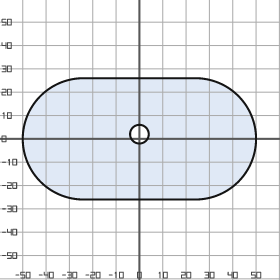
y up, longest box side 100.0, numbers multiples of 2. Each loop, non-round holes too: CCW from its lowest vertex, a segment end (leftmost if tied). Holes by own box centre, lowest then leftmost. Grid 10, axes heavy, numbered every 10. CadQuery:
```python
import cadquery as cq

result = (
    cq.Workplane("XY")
    .moveTo(-24.0, -26.0)
    .lineTo(24.0, -26.0)
    .threePointArc((50.0, 0.0), (24.0, 26.0))
    .lineTo(-24.0, 26.0)
    .threePointArc((-50.0, 0.0), (-24.0, -26.0))
    .close()
    .moveTo(0.0, 2.0)
    .circle(4.0)
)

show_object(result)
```